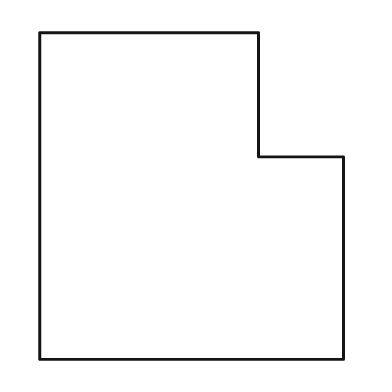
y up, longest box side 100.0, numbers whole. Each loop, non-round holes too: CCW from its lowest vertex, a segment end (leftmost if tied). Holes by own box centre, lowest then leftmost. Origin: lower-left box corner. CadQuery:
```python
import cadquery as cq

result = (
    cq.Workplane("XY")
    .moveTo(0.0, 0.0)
    .lineTo(93.0, 0.0)
    .lineTo(93.0, 62.0)
    .lineTo(67.0, 62.0)
    .lineTo(67.0, 100.0)
    .lineTo(0.0, 100.0)
    .close()
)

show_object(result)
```